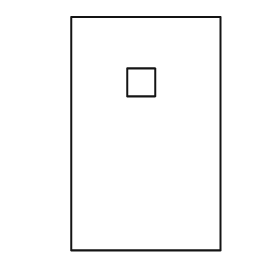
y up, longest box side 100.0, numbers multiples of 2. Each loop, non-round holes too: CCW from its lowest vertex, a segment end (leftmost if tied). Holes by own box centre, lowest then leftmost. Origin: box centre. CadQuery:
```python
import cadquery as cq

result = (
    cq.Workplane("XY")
    .moveTo(-32.0, -50.0)
    .lineTo(32.0, -50.0)
    .lineTo(32.0, 50.0)
    .lineTo(-32.0, 50.0)
    .close()
    .moveTo(-8.0, 16.0)
    .lineTo(4.0, 16.0)
    .lineTo(4.0, 28.0)
    .lineTo(-8.0, 28.0)
    .close()
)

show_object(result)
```